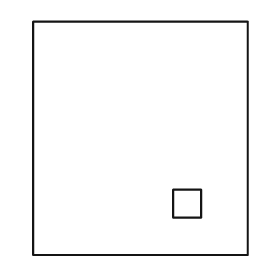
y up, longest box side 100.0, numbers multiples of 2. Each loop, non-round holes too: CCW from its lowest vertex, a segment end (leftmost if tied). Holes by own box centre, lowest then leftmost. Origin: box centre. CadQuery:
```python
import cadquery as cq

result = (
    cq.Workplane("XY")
    .moveTo(-46.0, -50.0)
    .lineTo(46.0, -50.0)
    .lineTo(46.0, 50.0)
    .lineTo(-46.0, 50.0)
    .close()
    .moveTo(14.0, -34.0)
    .lineTo(26.0, -34.0)
    .lineTo(26.0, -22.0)
    .lineTo(14.0, -22.0)
    .close()
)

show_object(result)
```